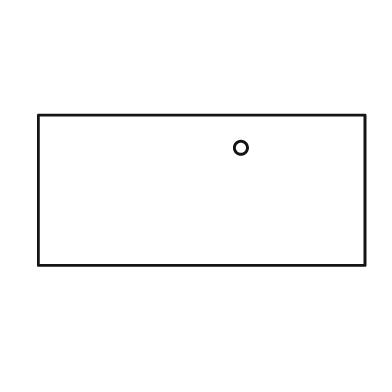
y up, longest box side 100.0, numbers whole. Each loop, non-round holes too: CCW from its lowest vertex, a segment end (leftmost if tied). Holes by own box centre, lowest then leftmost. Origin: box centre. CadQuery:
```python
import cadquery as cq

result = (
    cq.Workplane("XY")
    .moveTo(-50.0, -23.0)
    .lineTo(50.0, -23.0)
    .lineTo(50.0, 23.0)
    .lineTo(-50.0, 23.0)
    .close()
    .moveTo(12.0, 13.0)
    .circle(2.0)
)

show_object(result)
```